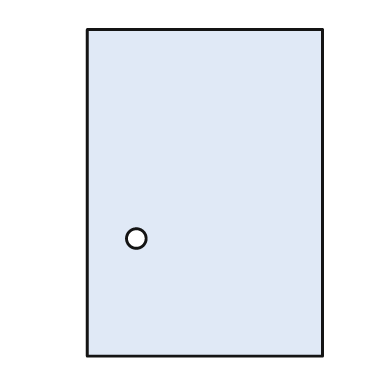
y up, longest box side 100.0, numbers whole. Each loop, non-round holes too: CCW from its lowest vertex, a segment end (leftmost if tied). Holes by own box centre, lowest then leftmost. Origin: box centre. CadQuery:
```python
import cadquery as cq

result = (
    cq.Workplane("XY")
    .moveTo(-36.0, -50.0)
    .lineTo(36.0, -50.0)
    .lineTo(36.0, 50.0)
    .lineTo(-36.0, 50.0)
    .close()
    .moveTo(-21.0, -14.0)
    .circle(3.0)
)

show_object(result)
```